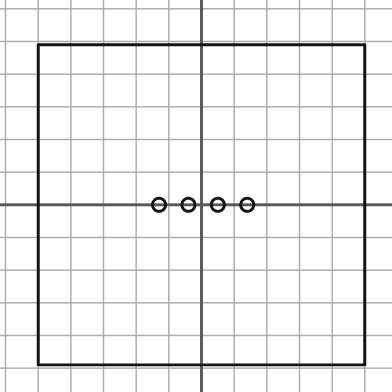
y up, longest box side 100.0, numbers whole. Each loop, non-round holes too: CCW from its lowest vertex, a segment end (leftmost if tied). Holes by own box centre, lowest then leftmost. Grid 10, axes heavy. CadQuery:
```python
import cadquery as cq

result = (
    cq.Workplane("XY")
    .moveTo(-50.0, -49.0)
    .lineTo(50.0, -49.0)
    .lineTo(50.0, 49.0)
    .lineTo(-50.0, 49.0)
    .close()
    .moveTo(-13.0, 0.0)
    .circle(2.0)
    .moveTo(-4.0, 0.0)
    .circle(2.0)
    .moveTo(5.0, 0.0)
    .circle(2.0)
    .moveTo(14.0, 0.0)
    .circle(2.0)
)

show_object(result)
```